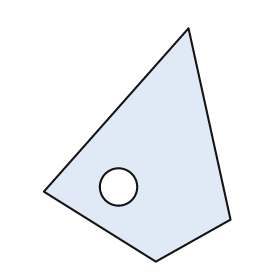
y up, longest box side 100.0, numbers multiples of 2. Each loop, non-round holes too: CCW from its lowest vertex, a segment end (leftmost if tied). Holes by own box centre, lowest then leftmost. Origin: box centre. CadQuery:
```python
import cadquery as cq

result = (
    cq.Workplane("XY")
    .moveTo(8.0, -50.0)
    .lineTo(40.0, -32.0)
    .lineTo(22.0, 50.0)
    .lineTo(-40.0, -20.0)
    .close()
    .moveTo(-8.0, -18.0)
    .circle(8.0)
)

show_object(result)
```